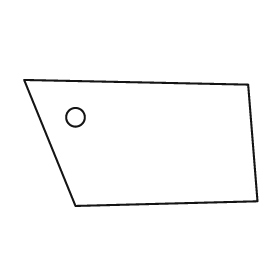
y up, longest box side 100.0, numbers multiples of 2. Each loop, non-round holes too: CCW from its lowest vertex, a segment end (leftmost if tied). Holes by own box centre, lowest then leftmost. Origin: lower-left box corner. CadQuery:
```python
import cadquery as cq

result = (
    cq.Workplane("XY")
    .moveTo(22.0, 0.0)
    .lineTo(100.0, 2.0)
    .lineTo(96.0, 52.0)
    .lineTo(0.0, 54.0)
    .close()
    .moveTo(22.0, 38.0)
    .circle(4.0)
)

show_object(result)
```